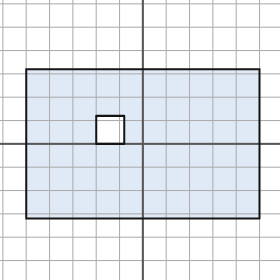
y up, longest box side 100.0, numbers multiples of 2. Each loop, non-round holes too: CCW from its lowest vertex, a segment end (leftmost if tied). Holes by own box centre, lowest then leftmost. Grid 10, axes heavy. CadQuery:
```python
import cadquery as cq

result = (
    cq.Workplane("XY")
    .moveTo(-50.0, -32.0)
    .lineTo(50.0, -32.0)
    .lineTo(50.0, 32.0)
    .lineTo(-50.0, 32.0)
    .close()
    .moveTo(-20.0, 0.0)
    .lineTo(-8.0, 0.0)
    .lineTo(-8.0, 12.0)
    .lineTo(-20.0, 12.0)
    .close()
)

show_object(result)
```